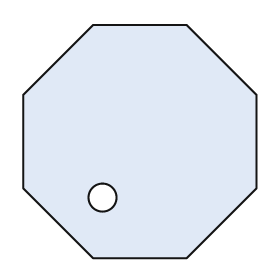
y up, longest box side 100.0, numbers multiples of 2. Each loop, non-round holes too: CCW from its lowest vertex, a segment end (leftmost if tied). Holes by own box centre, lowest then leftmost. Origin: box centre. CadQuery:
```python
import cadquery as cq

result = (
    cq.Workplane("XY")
    .moveTo(-20.0, -50.0)
    .lineTo(20.0, -50.0)
    .lineTo(50.0, -20.0)
    .lineTo(50.0, 20.0)
    .lineTo(20.0, 50.0)
    .lineTo(-20.0, 50.0)
    .lineTo(-50.0, 20.0)
    .lineTo(-50.0, -20.0)
    .close()
    .moveTo(-16.0, -24.0)
    .circle(6.0)
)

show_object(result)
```